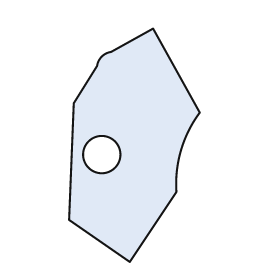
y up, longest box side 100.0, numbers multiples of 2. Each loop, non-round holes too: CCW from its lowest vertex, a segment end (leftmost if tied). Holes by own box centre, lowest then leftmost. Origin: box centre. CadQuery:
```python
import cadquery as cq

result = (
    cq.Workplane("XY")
    .moveTo(-2.0, -50.0)
    .lineTo(18.0, -20.0)
    .threePointArc((20.0, -2.0), (28.0, 14.0))
    .lineTo(8.0, 50.0)
    .lineTo(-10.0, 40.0)
    .threePointArc((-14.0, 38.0), (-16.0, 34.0))
    .lineTo(-26.0, 18.0)
    .lineTo(-28.0, -32.0)
    .close()
    .moveTo(-14.0, -4.0)
    .circle(8.0)
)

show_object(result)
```